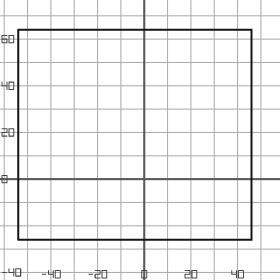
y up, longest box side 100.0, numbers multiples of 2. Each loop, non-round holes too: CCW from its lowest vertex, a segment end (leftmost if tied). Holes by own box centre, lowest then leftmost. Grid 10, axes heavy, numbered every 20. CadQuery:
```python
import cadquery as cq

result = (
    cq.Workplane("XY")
    .moveTo(-54.0, -26.0)
    .lineTo(46.0, -26.0)
    .lineTo(46.0, 64.0)
    .lineTo(-54.0, 64.0)
    .close()
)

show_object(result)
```